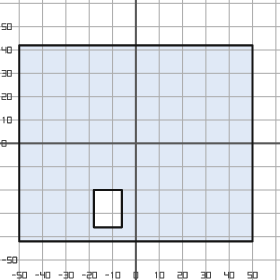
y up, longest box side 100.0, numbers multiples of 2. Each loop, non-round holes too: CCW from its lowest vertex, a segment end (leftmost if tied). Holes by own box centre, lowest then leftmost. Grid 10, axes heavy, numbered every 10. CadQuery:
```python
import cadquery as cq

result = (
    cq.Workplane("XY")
    .moveTo(-50.0, -42.0)
    .lineTo(50.0, -42.0)
    .lineTo(50.0, 42.0)
    .lineTo(-50.0, 42.0)
    .close()
    .moveTo(-18.0, -36.0)
    .lineTo(-6.0, -36.0)
    .lineTo(-6.0, -20.0)
    .lineTo(-18.0, -20.0)
    .close()
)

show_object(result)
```